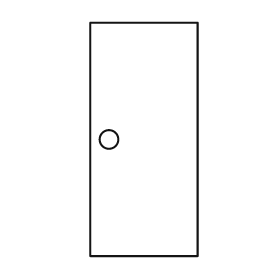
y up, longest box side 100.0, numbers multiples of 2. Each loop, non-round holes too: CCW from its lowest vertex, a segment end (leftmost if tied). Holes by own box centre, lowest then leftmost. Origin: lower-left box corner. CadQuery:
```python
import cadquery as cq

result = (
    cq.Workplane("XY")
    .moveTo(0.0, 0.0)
    .lineTo(46.0, 0.0)
    .lineTo(46.0, 100.0)
    .lineTo(0.0, 100.0)
    .close()
    .moveTo(8.0, 50.0)
    .circle(4.0)
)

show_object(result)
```